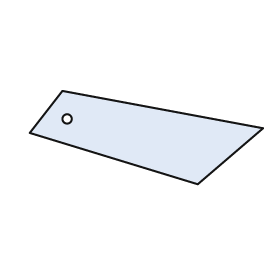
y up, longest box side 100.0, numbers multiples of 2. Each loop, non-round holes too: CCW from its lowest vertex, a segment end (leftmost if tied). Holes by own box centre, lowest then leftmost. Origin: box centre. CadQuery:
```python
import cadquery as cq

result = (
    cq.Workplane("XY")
    .moveTo(22.0, -20.0)
    .lineTo(50.0, 4.0)
    .lineTo(-36.0, 20.0)
    .lineTo(-50.0, 2.0)
    .close()
    .moveTo(-34.0, 8.0)
    .circle(2.0)
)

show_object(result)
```